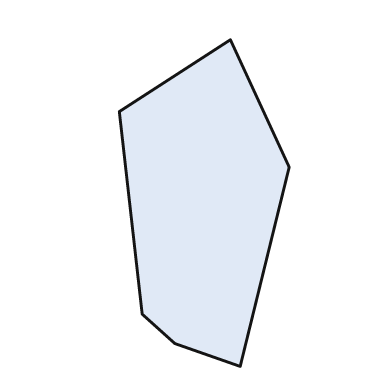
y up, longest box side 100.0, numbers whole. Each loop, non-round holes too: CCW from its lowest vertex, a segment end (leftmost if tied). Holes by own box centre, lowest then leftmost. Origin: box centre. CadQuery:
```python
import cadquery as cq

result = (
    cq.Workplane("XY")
    .moveTo(11.0, -50.0)
    .lineTo(26.0, 11.0)
    .lineTo(8.0, 50.0)
    .lineTo(-26.0, 28.0)
    .lineTo(-19.0, -34.0)
    .lineTo(-9.0, -43.0)
    .close()
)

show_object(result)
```